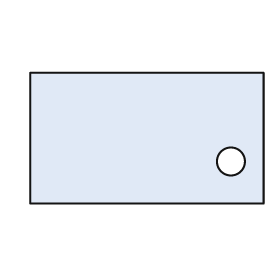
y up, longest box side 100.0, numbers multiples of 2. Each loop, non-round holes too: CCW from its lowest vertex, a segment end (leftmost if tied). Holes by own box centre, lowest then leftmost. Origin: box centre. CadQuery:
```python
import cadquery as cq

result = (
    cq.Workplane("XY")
    .moveTo(-50.0, -28.0)
    .lineTo(50.0, -28.0)
    .lineTo(50.0, 28.0)
    .lineTo(-50.0, 28.0)
    .close()
    .moveTo(36.0, -10.0)
    .circle(6.0)
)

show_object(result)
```